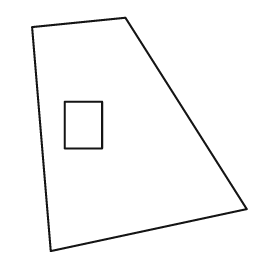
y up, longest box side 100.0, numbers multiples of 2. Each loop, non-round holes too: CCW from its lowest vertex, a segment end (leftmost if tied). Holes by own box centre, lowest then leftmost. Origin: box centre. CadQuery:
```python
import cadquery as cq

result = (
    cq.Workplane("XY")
    .moveTo(-38.0, -50.0)
    .lineTo(46.0, -32.0)
    .lineTo(-6.0, 50.0)
    .lineTo(-46.0, 46.0)
    .close()
    .moveTo(-32.0, -6.0)
    .lineTo(-16.0, -6.0)
    .lineTo(-16.0, 14.0)
    .lineTo(-32.0, 14.0)
    .close()
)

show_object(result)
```